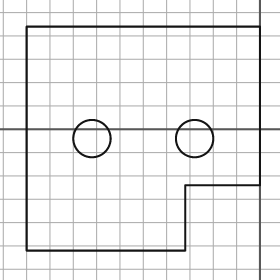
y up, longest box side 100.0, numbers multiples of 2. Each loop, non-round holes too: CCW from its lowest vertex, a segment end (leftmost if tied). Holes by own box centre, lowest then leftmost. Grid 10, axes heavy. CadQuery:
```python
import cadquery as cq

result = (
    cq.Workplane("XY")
    .moveTo(-100.0, -52.0)
    .lineTo(-32.0, -52.0)
    .lineTo(-32.0, -24.0)
    .lineTo(0.0, -24.0)
    .lineTo(0.0, 44.0)
    .lineTo(-100.0, 44.0)
    .close()
    .moveTo(-72.0, -4.0)
    .circle(8.0)
    .moveTo(-28.0, -4.0)
    .circle(8.0)
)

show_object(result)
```